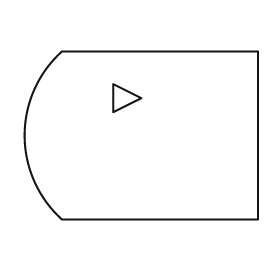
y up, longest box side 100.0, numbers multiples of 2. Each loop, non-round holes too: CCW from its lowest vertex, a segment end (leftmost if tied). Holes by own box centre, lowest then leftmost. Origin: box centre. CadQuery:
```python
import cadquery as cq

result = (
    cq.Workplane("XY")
    .moveTo(-34.0, -36.0)
    .lineTo(50.0, -36.0)
    .lineTo(50.0, 36.0)
    .lineTo(-34.0, 36.0)
    .threePointArc((-50.0, 0.0), (-34.0, -36.0))
    .close()
    .moveTo(-12.0, 10.0)
    .lineTo(0.0, 16.0)
    .lineTo(-12.0, 22.0)
    .close()
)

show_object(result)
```